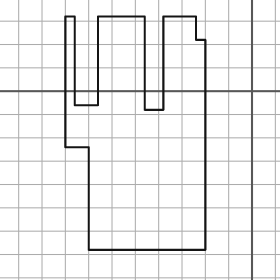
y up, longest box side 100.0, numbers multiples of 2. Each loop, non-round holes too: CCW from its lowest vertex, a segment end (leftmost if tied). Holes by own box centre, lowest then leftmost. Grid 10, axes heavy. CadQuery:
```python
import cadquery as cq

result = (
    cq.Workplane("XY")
    .moveTo(-70.0, -68.0)
    .lineTo(-20.0, -68.0)
    .lineTo(-20.0, 22.0)
    .lineTo(-24.0, 22.0)
    .lineTo(-24.0, 32.0)
    .lineTo(-38.0, 32.0)
    .lineTo(-38.0, -8.0)
    .lineTo(-46.0, -8.0)
    .lineTo(-46.0, 32.0)
    .lineTo(-66.0, 32.0)
    .lineTo(-66.0, -6.0)
    .lineTo(-76.0, -6.0)
    .lineTo(-76.0, 32.0)
    .lineTo(-80.0, 32.0)
    .lineTo(-80.0, -24.0)
    .lineTo(-70.0, -24.0)
    .close()
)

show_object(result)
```